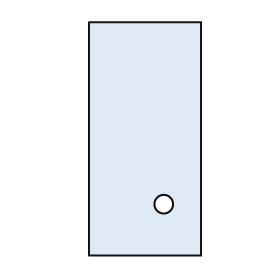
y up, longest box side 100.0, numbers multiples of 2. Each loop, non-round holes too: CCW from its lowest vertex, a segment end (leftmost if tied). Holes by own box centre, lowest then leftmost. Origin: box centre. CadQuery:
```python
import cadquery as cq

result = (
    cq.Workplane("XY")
    .moveTo(-24.0, -50.0)
    .lineTo(24.0, -50.0)
    .lineTo(24.0, 50.0)
    .lineTo(-24.0, 50.0)
    .close()
    .moveTo(8.0, -28.0)
    .circle(4.0)
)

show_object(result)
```